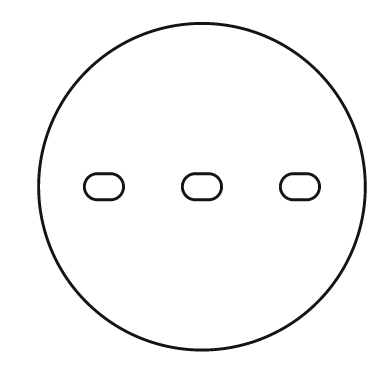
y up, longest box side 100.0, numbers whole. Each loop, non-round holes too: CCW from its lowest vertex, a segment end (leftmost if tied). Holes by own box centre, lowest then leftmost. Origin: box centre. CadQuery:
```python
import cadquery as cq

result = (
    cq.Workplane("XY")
    .moveTo(0.0, 0.0)
    .circle(50.0)
    .moveTo(-32.0, -4.0)
    .lineTo(-28.0, -4.0)
    .threePointArc((-24.0, 0.0), (-28.0, 4.0))
    .lineTo(-32.0, 4.0)
    .threePointArc((-36.0, 0.0), (-32.0, -4.0))
    .close()
    .moveTo(-2.0, -4.0)
    .lineTo(2.0, -4.0)
    .threePointArc((6.0, 0.0), (2.0, 4.0))
    .lineTo(-2.0, 4.0)
    .threePointArc((-6.0, 0.0), (-2.0, -4.0))
    .close()
    .moveTo(28.0, -4.0)
    .lineTo(32.0, -4.0)
    .threePointArc((36.0, 0.0), (32.0, 4.0))
    .lineTo(28.0, 4.0)
    .threePointArc((24.0, 0.0), (28.0, -4.0))
    .close()
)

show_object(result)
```